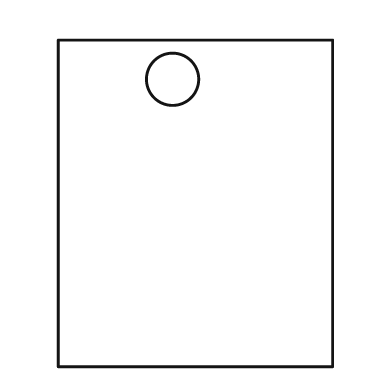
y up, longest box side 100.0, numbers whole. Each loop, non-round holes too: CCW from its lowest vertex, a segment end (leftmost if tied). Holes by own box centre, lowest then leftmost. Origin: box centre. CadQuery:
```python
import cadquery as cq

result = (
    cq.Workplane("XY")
    .moveTo(-42.0, -50.0)
    .lineTo(42.0, -50.0)
    .lineTo(42.0, 50.0)
    .lineTo(-42.0, 50.0)
    .close()
    .moveTo(-7.0, 38.0)
    .circle(8.0)
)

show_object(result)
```